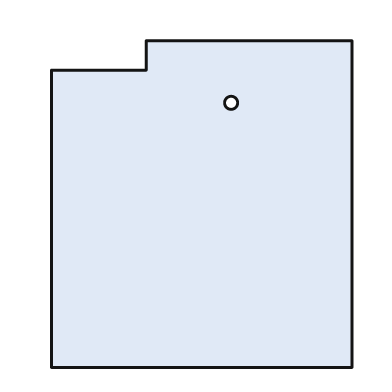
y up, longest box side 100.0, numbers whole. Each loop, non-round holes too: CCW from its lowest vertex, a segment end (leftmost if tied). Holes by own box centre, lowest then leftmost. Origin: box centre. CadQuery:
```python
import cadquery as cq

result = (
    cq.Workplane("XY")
    .moveTo(-46.0, -50.0)
    .lineTo(46.0, -50.0)
    .lineTo(46.0, 50.0)
    .lineTo(-17.0, 50.0)
    .lineTo(-17.0, 41.0)
    .lineTo(-46.0, 41.0)
    .close()
    .moveTo(9.0, 31.0)
    .circle(2.0)
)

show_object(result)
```